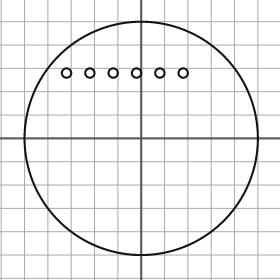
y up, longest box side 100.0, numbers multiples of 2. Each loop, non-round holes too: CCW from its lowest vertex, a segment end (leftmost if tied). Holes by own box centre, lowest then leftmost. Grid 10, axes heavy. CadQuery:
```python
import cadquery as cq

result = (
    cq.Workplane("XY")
    .moveTo(0.0, 0.0)
    .circle(50.0)
    .moveTo(-32.0, 28.0)
    .circle(2.0)
    .moveTo(-22.0, 28.0)
    .circle(2.0)
    .moveTo(-12.0, 28.0)
    .circle(2.0)
    .moveTo(-2.0, 28.0)
    .circle(2.0)
    .moveTo(8.0, 28.0)
    .circle(2.0)
    .moveTo(18.0, 28.0)
    .circle(2.0)
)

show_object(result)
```